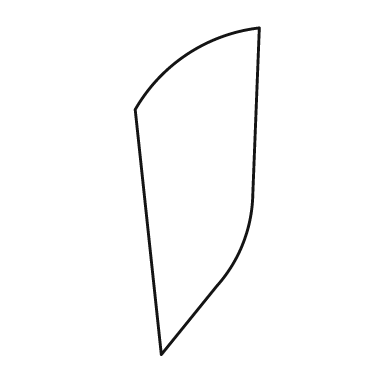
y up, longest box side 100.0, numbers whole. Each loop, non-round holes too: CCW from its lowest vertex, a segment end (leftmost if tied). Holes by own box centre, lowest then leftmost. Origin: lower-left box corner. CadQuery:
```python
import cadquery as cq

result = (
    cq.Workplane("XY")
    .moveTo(8.0, 0.0)
    .lineTo(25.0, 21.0)
    .threePointArc((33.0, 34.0), (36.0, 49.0))
    .lineTo(38.0, 100.0)
    .threePointArc((16.0, 92.0), (0.0, 75.0))
    .close()
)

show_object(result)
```